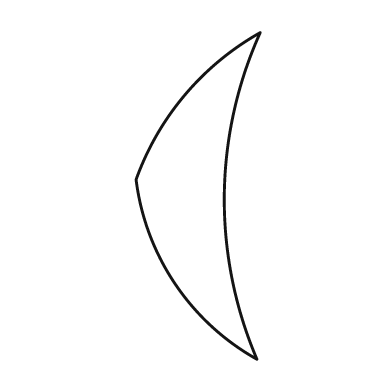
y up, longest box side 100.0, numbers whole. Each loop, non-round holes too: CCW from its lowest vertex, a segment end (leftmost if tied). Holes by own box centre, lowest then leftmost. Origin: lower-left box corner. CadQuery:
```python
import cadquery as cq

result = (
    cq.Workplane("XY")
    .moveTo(37.0, 0.0)
    .threePointArc((27.0, 50.0), (38.0, 100.0))
    .threePointArc((15.0, 81.0), (0.0, 55.0))
    .threePointArc((12.0, 23.0), (37.0, 0.0))
    .close()
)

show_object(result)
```